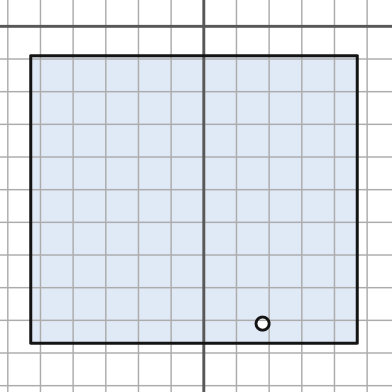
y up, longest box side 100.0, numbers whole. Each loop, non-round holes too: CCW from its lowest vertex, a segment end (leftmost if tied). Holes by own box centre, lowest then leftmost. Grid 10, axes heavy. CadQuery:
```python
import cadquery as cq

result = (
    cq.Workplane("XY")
    .moveTo(-53.0, -97.0)
    .lineTo(47.0, -97.0)
    .lineTo(47.0, -9.0)
    .lineTo(-53.0, -9.0)
    .close()
    .moveTo(18.0, -91.0)
    .circle(2.0)
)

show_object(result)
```